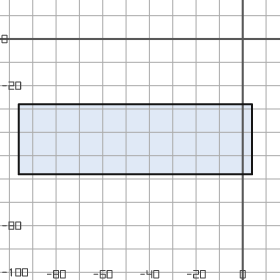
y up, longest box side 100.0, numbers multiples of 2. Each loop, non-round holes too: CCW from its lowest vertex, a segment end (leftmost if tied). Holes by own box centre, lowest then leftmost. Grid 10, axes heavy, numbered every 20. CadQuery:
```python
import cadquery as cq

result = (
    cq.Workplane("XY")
    .moveTo(-96.0, -58.0)
    .lineTo(4.0, -58.0)
    .lineTo(4.0, -28.0)
    .lineTo(-96.0, -28.0)
    .close()
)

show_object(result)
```